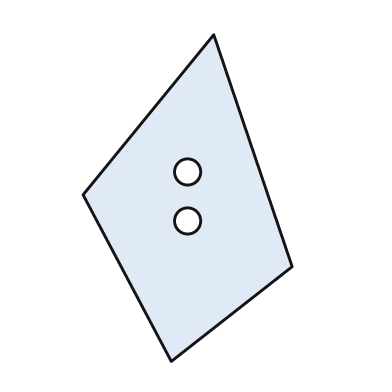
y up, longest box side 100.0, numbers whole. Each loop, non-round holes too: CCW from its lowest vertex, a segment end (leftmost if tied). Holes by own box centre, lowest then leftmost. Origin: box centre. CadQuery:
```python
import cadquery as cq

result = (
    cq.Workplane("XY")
    .moveTo(-5.0, -50.0)
    .lineTo(32.0, -21.0)
    .lineTo(8.0, 50.0)
    .lineTo(-32.0, 1.0)
    .close()
    .moveTo(0.0, -7.0)
    .circle(4.0)
    .moveTo(0.0, 8.0)
    .circle(4.0)
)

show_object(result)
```